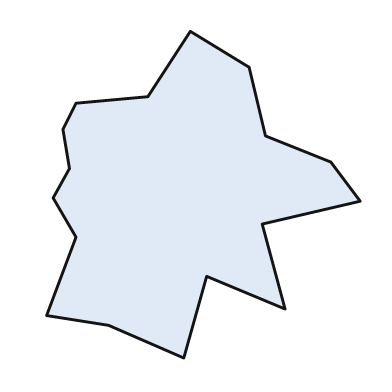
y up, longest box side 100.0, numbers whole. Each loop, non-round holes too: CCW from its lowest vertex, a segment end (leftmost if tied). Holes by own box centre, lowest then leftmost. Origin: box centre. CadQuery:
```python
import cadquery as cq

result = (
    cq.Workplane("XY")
    .moveTo(-6.0, -50.0)
    .lineTo(1.0, -25.0)
    .lineTo(25.0, -35.0)
    .lineTo(18.0, -9.0)
    .lineTo(48.0, -2.0)
    .lineTo(39.0, 10.0)
    .lineTo(19.0, 18.0)
    .lineTo(14.0, 39.0)
    .lineTo(-4.0, 50.0)
    .lineTo(-17.0, 30.0)
    .lineTo(-39.0, 28.0)
    .lineTo(-43.0, 20.0)
    .lineTo(-41.0, 8.0)
    .lineTo(-46.0, -1.0)
    .lineTo(-39.0, -13.0)
    .lineTo(-48.0, -37.0)
    .lineTo(-29.0, -40.0)
    .close()
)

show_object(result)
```